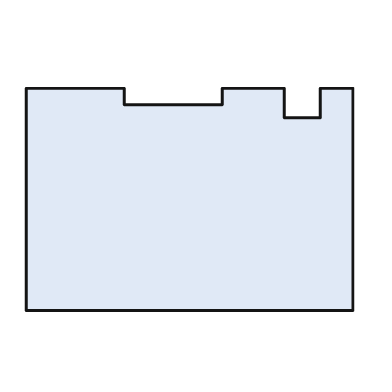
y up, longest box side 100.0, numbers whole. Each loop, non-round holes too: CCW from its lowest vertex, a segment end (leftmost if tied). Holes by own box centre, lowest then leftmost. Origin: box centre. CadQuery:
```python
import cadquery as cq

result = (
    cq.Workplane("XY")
    .moveTo(-50.0, -34.0)
    .lineTo(50.0, -34.0)
    .lineTo(50.0, 34.0)
    .lineTo(40.0, 34.0)
    .lineTo(40.0, 25.0)
    .lineTo(29.0, 25.0)
    .lineTo(29.0, 34.0)
    .lineTo(10.0, 34.0)
    .lineTo(10.0, 29.0)
    .lineTo(-20.0, 29.0)
    .lineTo(-20.0, 34.0)
    .lineTo(-50.0, 34.0)
    .close()
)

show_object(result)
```